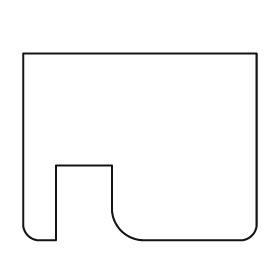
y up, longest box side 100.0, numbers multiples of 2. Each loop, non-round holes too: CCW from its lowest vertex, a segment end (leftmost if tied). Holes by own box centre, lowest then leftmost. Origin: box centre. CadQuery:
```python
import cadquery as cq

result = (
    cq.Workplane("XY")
    .moveTo(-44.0, -40.0)
    .lineTo(-36.0, -40.0)
    .lineTo(-36.0, -8.0)
    .lineTo(-12.0, -8.0)
    .lineTo(-12.0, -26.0)
    .threePointArc((-8.0, -36.0), (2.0, -40.0))
    .lineTo(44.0, -40.0)
    .threePointArc((48.0, -38.0), (50.0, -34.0))
    .lineTo(50.0, 40.0)
    .lineTo(-50.0, 40.0)
    .lineTo(-50.0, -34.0)
    .threePointArc((-48.0, -38.0), (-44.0, -40.0))
    .close()
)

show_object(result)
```